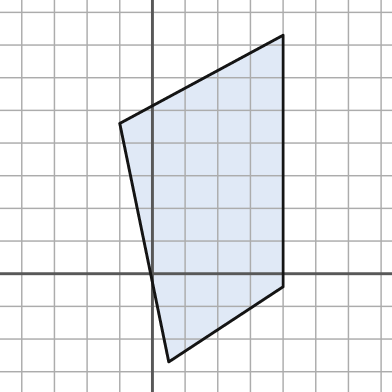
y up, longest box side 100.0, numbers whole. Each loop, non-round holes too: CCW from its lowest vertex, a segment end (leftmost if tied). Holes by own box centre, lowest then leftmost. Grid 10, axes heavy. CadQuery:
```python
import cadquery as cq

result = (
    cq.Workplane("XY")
    .moveTo(5.0, -27.0)
    .lineTo(40.0, -4.0)
    .lineTo(40.0, 73.0)
    .lineTo(-10.0, 46.0)
    .close()
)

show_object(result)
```